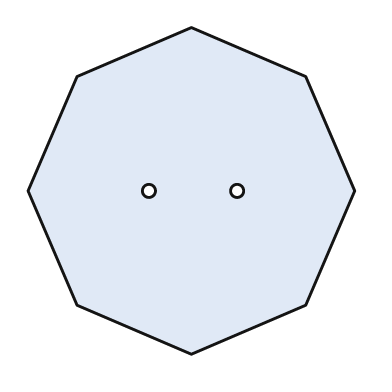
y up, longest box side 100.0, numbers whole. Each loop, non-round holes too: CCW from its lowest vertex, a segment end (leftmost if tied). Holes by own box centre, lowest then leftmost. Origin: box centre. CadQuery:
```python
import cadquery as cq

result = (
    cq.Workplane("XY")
    .moveTo(0.0, -50.0)
    .lineTo(35.0, -35.0)
    .lineTo(50.0, 0.0)
    .lineTo(35.0, 35.0)
    .lineTo(0.0, 50.0)
    .lineTo(-35.0, 35.0)
    .lineTo(-50.0, 0.0)
    .lineTo(-35.0, -35.0)
    .close()
    .moveTo(-13.0, 0.0)
    .circle(2.0)
    .moveTo(14.0, 0.0)
    .circle(2.0)
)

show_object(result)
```